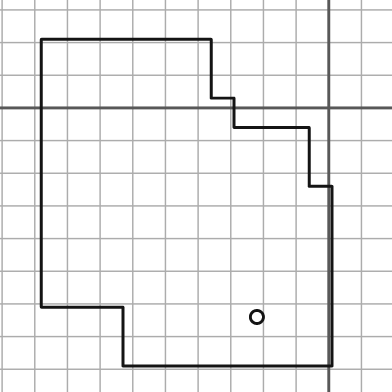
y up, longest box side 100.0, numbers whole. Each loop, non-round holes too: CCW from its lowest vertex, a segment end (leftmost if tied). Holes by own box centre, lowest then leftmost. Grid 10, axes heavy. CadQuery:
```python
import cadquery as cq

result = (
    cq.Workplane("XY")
    .moveTo(-63.0, -79.0)
    .lineTo(1.0, -79.0)
    .lineTo(1.0, -24.0)
    .lineTo(-6.0, -24.0)
    .lineTo(-6.0, -6.0)
    .lineTo(-29.0, -6.0)
    .lineTo(-29.0, 3.0)
    .lineTo(-36.0, 3.0)
    .lineTo(-36.0, 21.0)
    .lineTo(-88.0, 21.0)
    .lineTo(-88.0, -61.0)
    .lineTo(-63.0, -61.0)
    .close()
    .moveTo(-22.0, -64.0)
    .circle(2.0)
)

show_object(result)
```